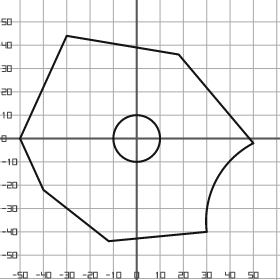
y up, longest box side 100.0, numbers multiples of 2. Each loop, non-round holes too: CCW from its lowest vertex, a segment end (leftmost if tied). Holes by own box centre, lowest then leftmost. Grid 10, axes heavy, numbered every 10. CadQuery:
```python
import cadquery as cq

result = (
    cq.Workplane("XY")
    .moveTo(-12.0, -44.0)
    .lineTo(30.0, -40.0)
    .threePointArc((34.0, -18.0), (50.0, -2.0))
    .lineTo(18.0, 36.0)
    .lineTo(-30.0, 44.0)
    .lineTo(-50.0, 0.0)
    .lineTo(-40.0, -22.0)
    .close()
    .moveTo(0.0, 0.0)
    .circle(10.0)
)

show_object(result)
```